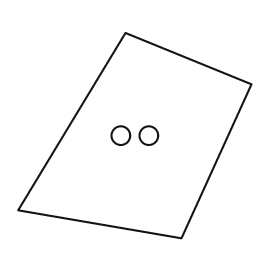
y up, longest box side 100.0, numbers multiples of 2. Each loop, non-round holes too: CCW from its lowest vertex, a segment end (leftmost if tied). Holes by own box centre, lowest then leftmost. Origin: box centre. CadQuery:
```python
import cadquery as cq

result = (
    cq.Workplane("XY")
    .moveTo(20.0, -44.0)
    .lineTo(50.0, 22.0)
    .lineTo(-4.0, 44.0)
    .lineTo(-50.0, -32.0)
    .close()
    .moveTo(-6.0, 0.0)
    .circle(4.0)
    .moveTo(6.0, 0.0)
    .circle(4.0)
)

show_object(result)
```